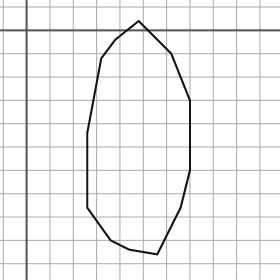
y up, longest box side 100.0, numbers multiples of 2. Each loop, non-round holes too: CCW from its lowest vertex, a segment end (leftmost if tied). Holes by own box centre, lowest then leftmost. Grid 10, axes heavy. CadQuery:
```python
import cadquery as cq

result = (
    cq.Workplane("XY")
    .moveTo(56.0, -96.0)
    .lineTo(66.0, -76.0)
    .lineTo(70.0, -60.0)
    .lineTo(70.0, -30.0)
    .lineTo(62.0, -10.0)
    .lineTo(48.0, 4.0)
    .lineTo(38.0, -4.0)
    .lineTo(32.0, -12.0)
    .lineTo(26.0, -44.0)
    .lineTo(26.0, -76.0)
    .lineTo(36.0, -90.0)
    .lineTo(44.0, -94.0)
    .close()
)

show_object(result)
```